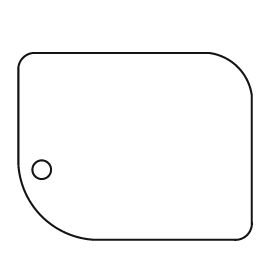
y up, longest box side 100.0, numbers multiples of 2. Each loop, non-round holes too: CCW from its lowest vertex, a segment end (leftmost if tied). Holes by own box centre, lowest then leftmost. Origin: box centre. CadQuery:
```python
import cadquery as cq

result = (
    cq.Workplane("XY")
    .moveTo(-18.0, -40.0)
    .lineTo(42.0, -40.0)
    .threePointArc((48.0, -38.0), (50.0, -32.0))
    .lineTo(50.0, 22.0)
    .threePointArc((44.0, 34.0), (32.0, 40.0))
    .lineTo(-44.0, 40.0)
    .threePointArc((-48.0, 38.0), (-50.0, 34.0))
    .lineTo(-50.0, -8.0)
    .threePointArc((-40.0, -30.0), (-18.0, -40.0))
    .close()
    .moveTo(-40.0, -10.0)
    .circle(4.0)
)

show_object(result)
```